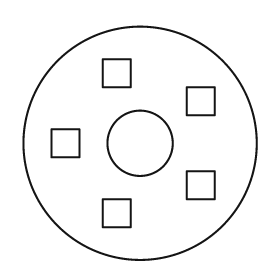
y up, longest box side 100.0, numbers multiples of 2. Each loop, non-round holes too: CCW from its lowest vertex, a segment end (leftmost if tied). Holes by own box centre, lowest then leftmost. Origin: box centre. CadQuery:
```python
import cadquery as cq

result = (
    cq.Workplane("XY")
    .moveTo(0.0, 0.0)
    .circle(50.0)
    .moveTo(-16.0, -36.0)
    .lineTo(-4.0, -36.0)
    .lineTo(-4.0, -24.0)
    .lineTo(-16.0, -24.0)
    .close()
    .moveTo(20.0, -24.0)
    .lineTo(32.0, -24.0)
    .lineTo(32.0, -12.0)
    .lineTo(20.0, -12.0)
    .close()
    .moveTo(-38.0, -6.0)
    .lineTo(-26.0, -6.0)
    .lineTo(-26.0, 6.0)
    .lineTo(-38.0, 6.0)
    .close()
    .moveTo(0.0, 0.0)
    .circle(14.0)
    .moveTo(20.0, 12.0)
    .lineTo(32.0, 12.0)
    .lineTo(32.0, 24.0)
    .lineTo(20.0, 24.0)
    .close()
    .moveTo(-16.0, 24.0)
    .lineTo(-4.0, 24.0)
    .lineTo(-4.0, 36.0)
    .lineTo(-16.0, 36.0)
    .close()
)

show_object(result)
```